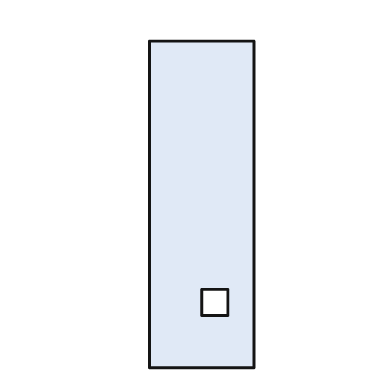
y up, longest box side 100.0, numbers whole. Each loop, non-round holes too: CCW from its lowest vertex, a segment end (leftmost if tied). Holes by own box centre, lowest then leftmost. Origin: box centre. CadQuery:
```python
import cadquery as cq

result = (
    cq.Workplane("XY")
    .moveTo(-16.0, -50.0)
    .lineTo(16.0, -50.0)
    .lineTo(16.0, 50.0)
    .lineTo(-16.0, 50.0)
    .close()
    .moveTo(0.0, -34.0)
    .lineTo(8.0, -34.0)
    .lineTo(8.0, -26.0)
    .lineTo(0.0, -26.0)
    .close()
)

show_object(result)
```